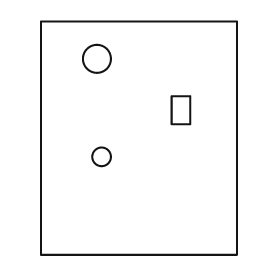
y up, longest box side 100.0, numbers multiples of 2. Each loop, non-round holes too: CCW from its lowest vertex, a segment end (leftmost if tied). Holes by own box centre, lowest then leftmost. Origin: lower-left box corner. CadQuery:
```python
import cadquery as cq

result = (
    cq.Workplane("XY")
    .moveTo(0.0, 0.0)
    .lineTo(84.0, 0.0)
    .lineTo(84.0, 100.0)
    .lineTo(0.0, 100.0)
    .close()
    .moveTo(26.0, 42.0)
    .circle(4.0)
    .moveTo(56.0, 56.0)
    .lineTo(64.0, 56.0)
    .lineTo(64.0, 68.0)
    .lineTo(56.0, 68.0)
    .close()
    .moveTo(24.0, 84.0)
    .circle(6.0)
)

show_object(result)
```